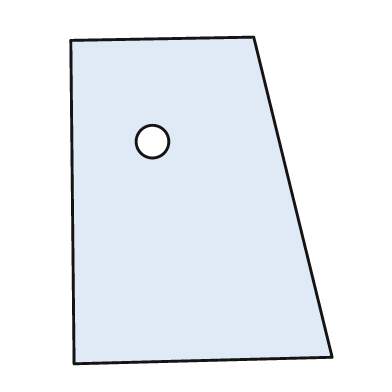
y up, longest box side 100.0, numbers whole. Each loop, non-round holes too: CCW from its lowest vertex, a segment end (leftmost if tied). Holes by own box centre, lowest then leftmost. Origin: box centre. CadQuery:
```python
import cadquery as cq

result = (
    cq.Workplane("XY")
    .moveTo(-39.0, -50.0)
    .lineTo(40.0, -48.0)
    .lineTo(16.0, 50.0)
    .lineTo(-40.0, 49.0)
    .close()
    .moveTo(-15.0, 18.0)
    .circle(5.0)
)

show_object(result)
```